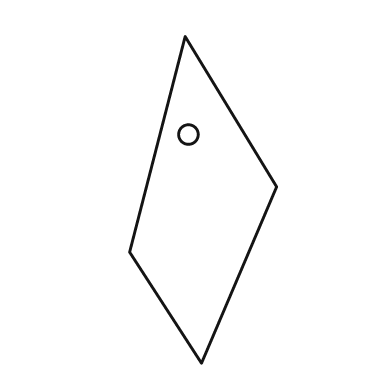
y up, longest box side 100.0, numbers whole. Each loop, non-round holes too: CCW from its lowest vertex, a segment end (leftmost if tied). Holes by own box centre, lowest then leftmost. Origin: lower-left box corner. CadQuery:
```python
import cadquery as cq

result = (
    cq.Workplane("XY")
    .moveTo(22.0, 0.0)
    .lineTo(45.0, 54.0)
    .lineTo(17.0, 100.0)
    .lineTo(0.0, 34.0)
    .close()
    .moveTo(18.0, 70.0)
    .circle(3.0)
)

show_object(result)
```